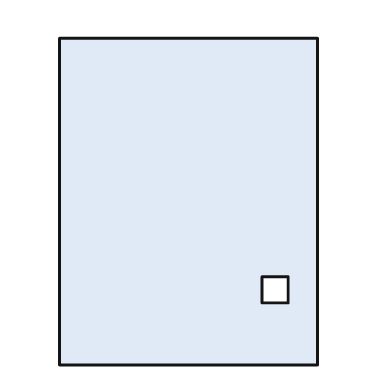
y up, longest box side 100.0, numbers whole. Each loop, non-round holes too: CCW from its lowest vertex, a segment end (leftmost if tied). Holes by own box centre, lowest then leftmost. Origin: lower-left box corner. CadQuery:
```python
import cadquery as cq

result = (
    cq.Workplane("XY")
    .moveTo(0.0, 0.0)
    .lineTo(79.0, 0.0)
    .lineTo(79.0, 100.0)
    .lineTo(0.0, 100.0)
    .close()
    .moveTo(62.0, 19.0)
    .lineTo(70.0, 19.0)
    .lineTo(70.0, 27.0)
    .lineTo(62.0, 27.0)
    .close()
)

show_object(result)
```